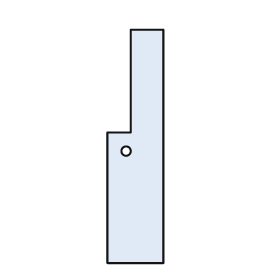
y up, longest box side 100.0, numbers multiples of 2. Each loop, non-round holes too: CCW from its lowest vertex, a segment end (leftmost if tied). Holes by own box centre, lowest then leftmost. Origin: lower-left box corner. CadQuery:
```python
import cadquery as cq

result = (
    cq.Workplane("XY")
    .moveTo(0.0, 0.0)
    .lineTo(24.0, 0.0)
    .lineTo(24.0, 100.0)
    .lineTo(10.0, 100.0)
    .lineTo(10.0, 56.0)
    .lineTo(0.0, 56.0)
    .close()
    .moveTo(8.0, 48.0)
    .circle(2.0)
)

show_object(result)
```